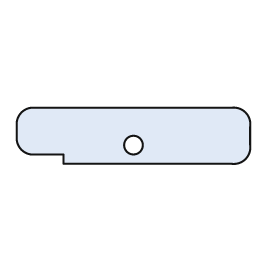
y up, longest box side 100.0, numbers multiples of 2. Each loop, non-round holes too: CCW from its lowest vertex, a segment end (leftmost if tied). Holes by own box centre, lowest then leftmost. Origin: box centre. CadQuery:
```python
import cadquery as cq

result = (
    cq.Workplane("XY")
    .moveTo(-30.0, -12.0)
    .lineTo(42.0, -12.0)
    .threePointArc((48.0, -10.0), (50.0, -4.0))
    .lineTo(50.0, 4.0)
    .threePointArc((48.0, 10.0), (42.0, 12.0))
    .lineTo(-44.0, 12.0)
    .threePointArc((-48.0, 10.0), (-50.0, 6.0))
    .lineTo(-50.0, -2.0)
    .threePointArc((-48.0, -6.0), (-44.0, -8.0))
    .lineTo(-30.0, -8.0)
    .close()
    .moveTo(0.0, -4.0)
    .circle(4.0)
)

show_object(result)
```